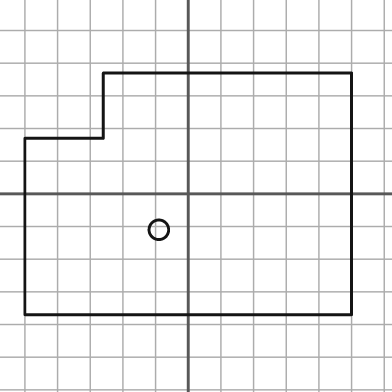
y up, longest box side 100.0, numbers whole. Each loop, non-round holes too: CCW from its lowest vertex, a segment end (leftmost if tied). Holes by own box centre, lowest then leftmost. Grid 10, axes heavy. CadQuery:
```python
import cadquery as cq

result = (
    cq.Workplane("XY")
    .moveTo(-50.0, -37.0)
    .lineTo(50.0, -37.0)
    .lineTo(50.0, 37.0)
    .lineTo(-26.0, 37.0)
    .lineTo(-26.0, 17.0)
    .lineTo(-50.0, 17.0)
    .close()
    .moveTo(-9.0, -11.0)
    .circle(3.0)
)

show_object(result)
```